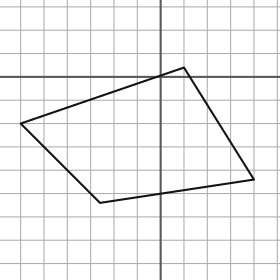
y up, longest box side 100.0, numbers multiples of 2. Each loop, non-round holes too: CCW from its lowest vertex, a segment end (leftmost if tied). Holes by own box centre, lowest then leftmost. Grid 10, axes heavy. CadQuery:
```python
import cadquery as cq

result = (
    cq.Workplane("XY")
    .moveTo(-26.0, -54.0)
    .lineTo(40.0, -44.0)
    .lineTo(10.0, 4.0)
    .lineTo(-60.0, -20.0)
    .close()
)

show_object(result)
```